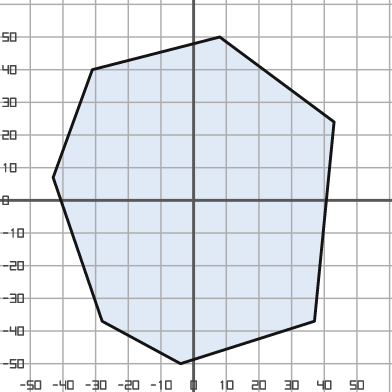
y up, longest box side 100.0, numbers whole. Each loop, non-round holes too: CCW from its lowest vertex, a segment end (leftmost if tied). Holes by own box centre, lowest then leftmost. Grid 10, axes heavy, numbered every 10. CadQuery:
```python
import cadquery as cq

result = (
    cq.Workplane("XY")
    .moveTo(-4.0, -50.0)
    .lineTo(37.0, -37.0)
    .lineTo(43.0, 24.0)
    .lineTo(8.0, 50.0)
    .lineTo(-31.0, 40.0)
    .lineTo(-43.0, 7.0)
    .lineTo(-28.0, -37.0)
    .close()
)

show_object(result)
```